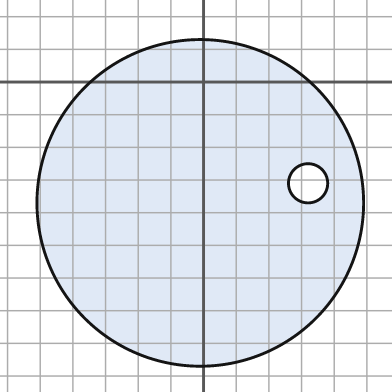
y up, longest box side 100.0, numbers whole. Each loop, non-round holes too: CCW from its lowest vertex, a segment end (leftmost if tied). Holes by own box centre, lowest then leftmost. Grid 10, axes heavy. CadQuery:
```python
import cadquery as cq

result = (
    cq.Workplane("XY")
    .moveTo(-1.0, -37.0)
    .circle(50.0)
    .moveTo(32.0, -31.0)
    .circle(6.0)
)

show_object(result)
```